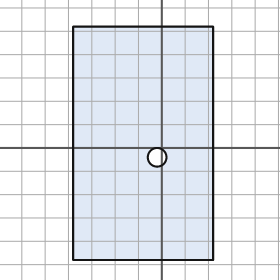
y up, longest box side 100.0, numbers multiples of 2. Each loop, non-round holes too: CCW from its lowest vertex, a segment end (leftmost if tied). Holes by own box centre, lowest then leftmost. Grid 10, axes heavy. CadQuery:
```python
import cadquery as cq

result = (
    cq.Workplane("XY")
    .moveTo(-38.0, -48.0)
    .lineTo(22.0, -48.0)
    .lineTo(22.0, 52.0)
    .lineTo(-38.0, 52.0)
    .close()
    .moveTo(-2.0, -4.0)
    .circle(4.0)
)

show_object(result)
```